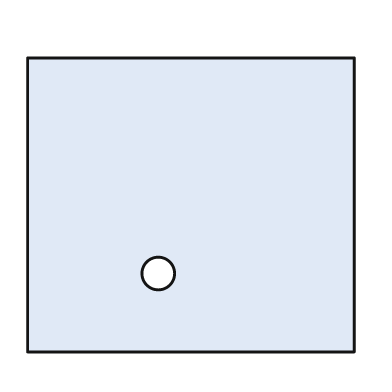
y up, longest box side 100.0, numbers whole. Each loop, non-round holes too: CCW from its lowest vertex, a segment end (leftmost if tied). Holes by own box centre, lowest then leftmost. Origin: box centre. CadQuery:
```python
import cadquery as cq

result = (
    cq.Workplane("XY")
    .moveTo(-50.0, -45.0)
    .lineTo(50.0, -45.0)
    .lineTo(50.0, 45.0)
    .lineTo(-50.0, 45.0)
    .close()
    .moveTo(-10.0, -21.0)
    .circle(5.0)
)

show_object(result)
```